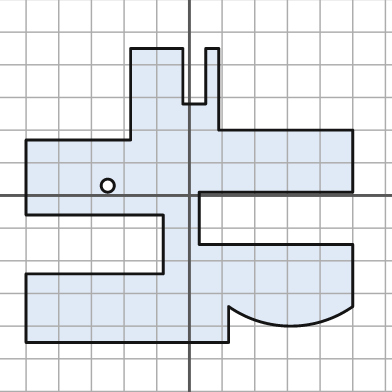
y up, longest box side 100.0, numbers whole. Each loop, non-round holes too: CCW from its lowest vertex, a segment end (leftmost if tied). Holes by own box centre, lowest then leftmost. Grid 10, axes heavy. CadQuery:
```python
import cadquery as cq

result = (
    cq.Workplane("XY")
    .moveTo(-50.0, -45.0)
    .lineTo(12.0, -45.0)
    .lineTo(12.0, -34.0)
    .threePointArc((31.0, -40.0), (50.0, -34.0))
    .lineTo(50.0, -15.0)
    .lineTo(3.0, -15.0)
    .lineTo(3.0, 1.0)
    .lineTo(50.0, 1.0)
    .lineTo(50.0, 20.0)
    .lineTo(9.0, 20.0)
    .lineTo(9.0, 45.0)
    .lineTo(5.0, 45.0)
    .lineTo(5.0, 28.0)
    .lineTo(-2.0, 28.0)
    .lineTo(-2.0, 45.0)
    .lineTo(-18.0, 45.0)
    .lineTo(-18.0, 17.0)
    .lineTo(-50.0, 17.0)
    .lineTo(-50.0, -6.0)
    .lineTo(-8.0, -6.0)
    .lineTo(-8.0, -24.0)
    .lineTo(-50.0, -24.0)
    .close()
    .moveTo(-25.0, 3.0)
    .circle(2.0)
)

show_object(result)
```